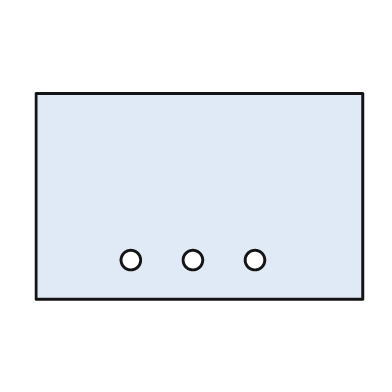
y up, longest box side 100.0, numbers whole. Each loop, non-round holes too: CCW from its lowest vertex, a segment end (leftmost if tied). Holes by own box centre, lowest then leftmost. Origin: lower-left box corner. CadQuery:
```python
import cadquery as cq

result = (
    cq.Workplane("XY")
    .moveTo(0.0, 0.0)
    .lineTo(100.0, 0.0)
    .lineTo(100.0, 63.0)
    .lineTo(0.0, 63.0)
    .close()
    .moveTo(29.0, 12.0)
    .circle(3.0)
    .moveTo(48.0, 12.0)
    .circle(3.0)
    .moveTo(67.0, 12.0)
    .circle(3.0)
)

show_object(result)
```